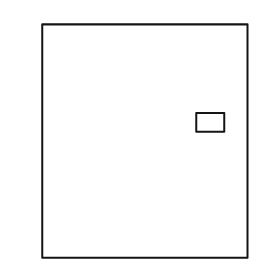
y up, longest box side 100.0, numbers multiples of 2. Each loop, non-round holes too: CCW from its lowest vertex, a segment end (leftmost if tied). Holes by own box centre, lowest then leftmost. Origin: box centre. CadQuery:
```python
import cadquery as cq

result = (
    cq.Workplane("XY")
    .moveTo(-44.0, -50.0)
    .lineTo(44.0, -50.0)
    .lineTo(44.0, 50.0)
    .lineTo(-44.0, 50.0)
    .close()
    .moveTo(22.0, 4.0)
    .lineTo(34.0, 4.0)
    .lineTo(34.0, 12.0)
    .lineTo(22.0, 12.0)
    .close()
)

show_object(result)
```